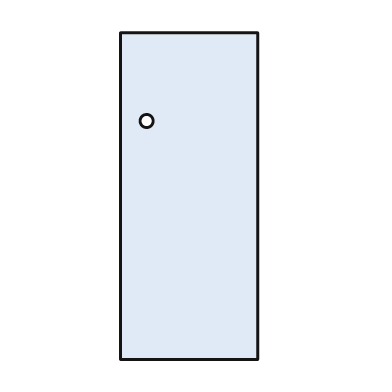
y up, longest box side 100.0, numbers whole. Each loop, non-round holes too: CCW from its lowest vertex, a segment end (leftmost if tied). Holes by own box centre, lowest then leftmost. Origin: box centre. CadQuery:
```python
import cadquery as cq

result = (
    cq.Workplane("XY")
    .moveTo(-21.0, -50.0)
    .lineTo(21.0, -50.0)
    .lineTo(21.0, 50.0)
    .lineTo(-21.0, 50.0)
    .close()
    .moveTo(-13.0, 23.0)
    .circle(2.0)
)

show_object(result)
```